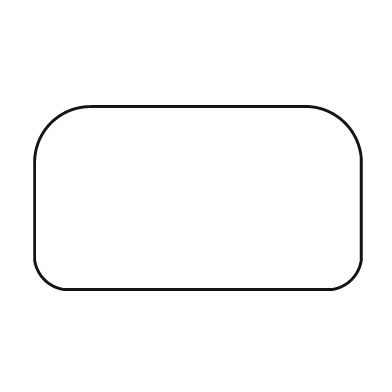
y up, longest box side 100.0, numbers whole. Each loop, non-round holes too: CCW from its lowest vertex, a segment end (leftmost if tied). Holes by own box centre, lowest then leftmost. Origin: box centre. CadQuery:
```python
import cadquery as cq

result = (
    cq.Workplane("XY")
    .moveTo(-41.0, -28.0)
    .lineTo(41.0, -28.0)
    .threePointArc((47.0, -25.0), (50.0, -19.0))
    .lineTo(50.0, 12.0)
    .threePointArc((45.0, 23.0), (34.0, 28.0))
    .lineTo(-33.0, 28.0)
    .threePointArc((-45.0, 23.0), (-50.0, 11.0))
    .lineTo(-50.0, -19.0)
    .threePointArc((-47.0, -25.0), (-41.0, -28.0))
    .close()
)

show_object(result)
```